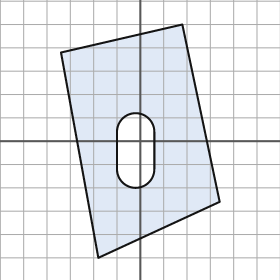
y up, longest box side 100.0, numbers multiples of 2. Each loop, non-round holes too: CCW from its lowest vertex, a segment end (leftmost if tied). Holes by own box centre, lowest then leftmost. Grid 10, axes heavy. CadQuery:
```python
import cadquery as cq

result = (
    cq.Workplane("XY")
    .moveTo(-18.0, -50.0)
    .lineTo(34.0, -26.0)
    .lineTo(18.0, 50.0)
    .lineTo(-34.0, 38.0)
    .close()
    .moveTo(-10.0, -12.0)
    .threePointArc((-2.0, -20.0), (6.0, -12.0))
    .lineTo(6.0, 4.0)
    .threePointArc((-2.0, 12.0), (-10.0, 4.0))
    .close()
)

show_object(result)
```